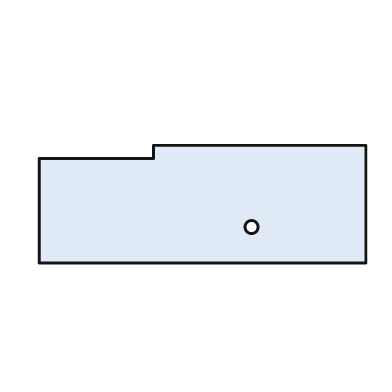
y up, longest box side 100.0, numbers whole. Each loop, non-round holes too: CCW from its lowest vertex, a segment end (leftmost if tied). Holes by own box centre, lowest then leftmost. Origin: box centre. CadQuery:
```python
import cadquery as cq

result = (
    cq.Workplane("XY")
    .moveTo(-50.0, -18.0)
    .lineTo(50.0, -18.0)
    .lineTo(50.0, 18.0)
    .lineTo(-15.0, 18.0)
    .lineTo(-15.0, 14.0)
    .lineTo(-50.0, 14.0)
    .close()
    .moveTo(15.0, -7.0)
    .circle(2.0)
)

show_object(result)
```